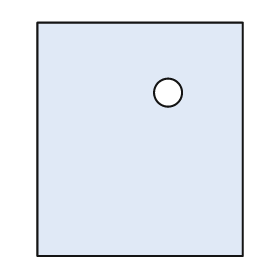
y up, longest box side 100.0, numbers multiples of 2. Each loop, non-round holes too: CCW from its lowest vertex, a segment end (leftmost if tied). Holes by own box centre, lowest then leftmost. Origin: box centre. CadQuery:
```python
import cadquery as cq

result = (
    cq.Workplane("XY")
    .moveTo(-44.0, -50.0)
    .lineTo(44.0, -50.0)
    .lineTo(44.0, 50.0)
    .lineTo(-44.0, 50.0)
    .close()
    .moveTo(12.0, 20.0)
    .circle(6.0)
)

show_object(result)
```